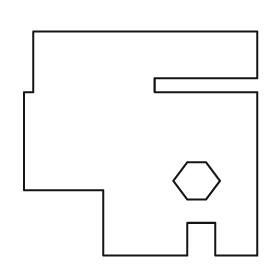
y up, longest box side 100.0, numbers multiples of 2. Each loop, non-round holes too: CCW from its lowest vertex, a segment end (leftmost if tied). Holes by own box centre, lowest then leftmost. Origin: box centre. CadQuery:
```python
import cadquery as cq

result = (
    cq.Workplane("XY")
    .moveTo(-16.0, -48.0)
    .lineTo(20.0, -48.0)
    .lineTo(20.0, -34.0)
    .lineTo(32.0, -34.0)
    .lineTo(32.0, -48.0)
    .lineTo(50.0, -48.0)
    .lineTo(50.0, 22.0)
    .lineTo(6.0, 22.0)
    .lineTo(6.0, 28.0)
    .lineTo(50.0, 28.0)
    .lineTo(50.0, 48.0)
    .lineTo(-46.0, 48.0)
    .lineTo(-46.0, 22.0)
    .lineTo(-50.0, 22.0)
    .lineTo(-50.0, -20.0)
    .lineTo(-16.0, -20.0)
    .close()
    .moveTo(20.0, -24.0)
    .lineTo(28.0, -24.0)
    .lineTo(34.0, -16.0)
    .lineTo(28.0, -8.0)
    .lineTo(20.0, -8.0)
    .lineTo(14.0, -16.0)
    .close()
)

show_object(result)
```